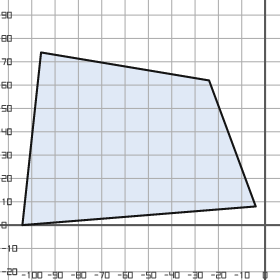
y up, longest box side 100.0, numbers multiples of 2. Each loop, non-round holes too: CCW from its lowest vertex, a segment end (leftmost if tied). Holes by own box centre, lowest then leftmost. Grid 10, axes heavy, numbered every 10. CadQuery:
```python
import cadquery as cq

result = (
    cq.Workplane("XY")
    .moveTo(-104.0, 0.0)
    .lineTo(-4.0, 8.0)
    .lineTo(-24.0, 62.0)
    .lineTo(-96.0, 74.0)
    .close()
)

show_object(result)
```